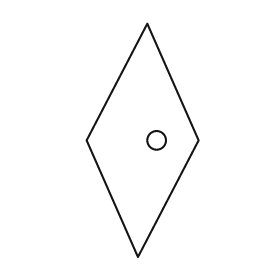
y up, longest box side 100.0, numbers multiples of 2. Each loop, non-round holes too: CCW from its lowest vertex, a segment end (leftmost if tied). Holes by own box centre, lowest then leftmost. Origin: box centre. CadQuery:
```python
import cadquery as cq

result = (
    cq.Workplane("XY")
    .moveTo(-2.0, -50.0)
    .lineTo(24.0, 0.0)
    .lineTo(2.0, 50.0)
    .lineTo(-24.0, 0.0)
    .close()
    .moveTo(6.0, 0.0)
    .circle(4.0)
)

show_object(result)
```